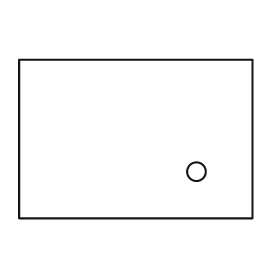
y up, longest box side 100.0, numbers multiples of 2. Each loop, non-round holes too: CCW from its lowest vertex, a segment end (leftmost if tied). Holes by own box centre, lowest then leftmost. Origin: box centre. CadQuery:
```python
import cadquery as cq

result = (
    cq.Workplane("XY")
    .moveTo(-50.0, -34.0)
    .lineTo(50.0, -34.0)
    .lineTo(50.0, 34.0)
    .lineTo(-50.0, 34.0)
    .close()
    .moveTo(26.0, -14.0)
    .circle(4.0)
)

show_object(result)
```